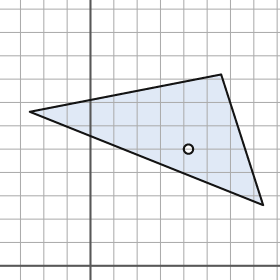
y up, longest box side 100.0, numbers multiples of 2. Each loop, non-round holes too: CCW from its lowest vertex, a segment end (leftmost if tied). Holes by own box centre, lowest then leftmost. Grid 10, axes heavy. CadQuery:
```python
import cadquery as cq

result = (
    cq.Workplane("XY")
    .moveTo(74.0, 26.0)
    .lineTo(56.0, 82.0)
    .lineTo(-26.0, 66.0)
    .close()
    .moveTo(42.0, 50.0)
    .circle(2.0)
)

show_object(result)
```